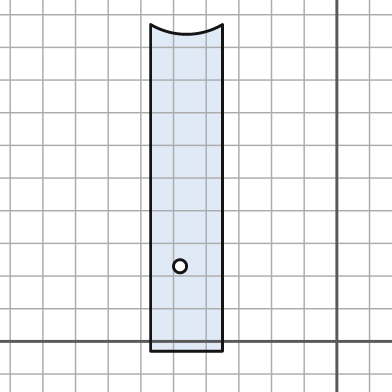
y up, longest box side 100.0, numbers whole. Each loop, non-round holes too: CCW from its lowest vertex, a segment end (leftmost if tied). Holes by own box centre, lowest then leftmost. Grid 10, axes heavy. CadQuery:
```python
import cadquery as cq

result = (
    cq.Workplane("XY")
    .moveTo(-57.0, -3.0)
    .lineTo(-35.0, -3.0)
    .lineTo(-35.0, 97.0)
    .threePointArc((-46.0, 94.0), (-57.0, 97.0))
    .close()
    .moveTo(-48.0, 23.0)
    .circle(2.0)
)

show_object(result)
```